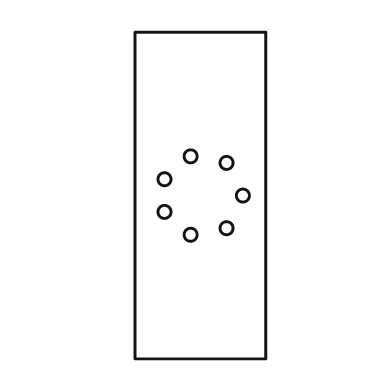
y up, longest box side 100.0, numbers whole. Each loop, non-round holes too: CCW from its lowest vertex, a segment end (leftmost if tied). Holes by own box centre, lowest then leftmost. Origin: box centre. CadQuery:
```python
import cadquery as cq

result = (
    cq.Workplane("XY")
    .moveTo(-20.0, -50.0)
    .lineTo(20.0, -50.0)
    .lineTo(20.0, 50.0)
    .lineTo(-20.0, 50.0)
    .close()
    .moveTo(-3.0, -12.0)
    .circle(2.0)
    .moveTo(8.0, -10.0)
    .circle(2.0)
    .moveTo(-11.0, -5.0)
    .circle(2.0)
    .moveTo(13.0, 0.0)
    .circle(2.0)
    .moveTo(-11.0, 5.0)
    .circle(2.0)
    .moveTo(8.0, 10.0)
    .circle(2.0)
    .moveTo(-3.0, 12.0)
    .circle(2.0)
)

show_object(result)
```